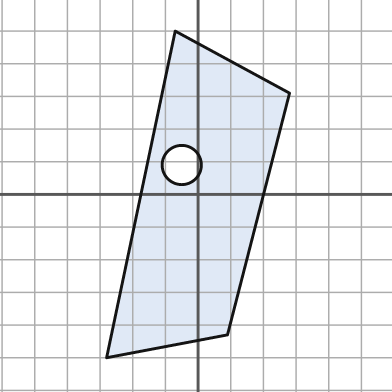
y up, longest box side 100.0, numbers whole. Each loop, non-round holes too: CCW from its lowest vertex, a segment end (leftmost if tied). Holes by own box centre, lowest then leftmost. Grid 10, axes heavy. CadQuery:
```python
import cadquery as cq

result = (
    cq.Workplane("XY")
    .moveTo(-28.0, -50.0)
    .lineTo(9.0, -43.0)
    .lineTo(28.0, 31.0)
    .lineTo(-7.0, 50.0)
    .close()
    .moveTo(-5.0, 9.0)
    .circle(6.0)
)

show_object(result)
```